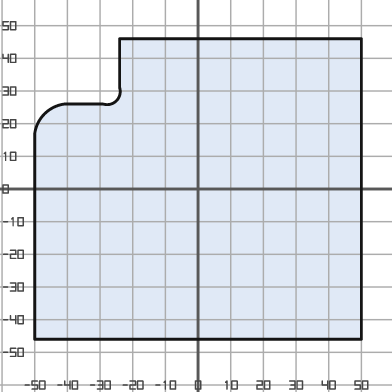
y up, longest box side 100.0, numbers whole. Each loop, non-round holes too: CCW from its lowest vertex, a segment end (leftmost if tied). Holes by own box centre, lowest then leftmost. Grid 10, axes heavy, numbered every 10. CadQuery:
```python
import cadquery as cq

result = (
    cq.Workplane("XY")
    .moveTo(-50.0, -46.0)
    .lineTo(50.0, -46.0)
    .lineTo(50.0, 46.0)
    .lineTo(-24.0, 46.0)
    .lineTo(-24.0, 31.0)
    .threePointArc((-25.0, 27.0), (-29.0, 26.0))
    .lineTo(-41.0, 26.0)
    .threePointArc((-47.0, 23.0), (-50.0, 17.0))
    .close()
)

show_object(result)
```